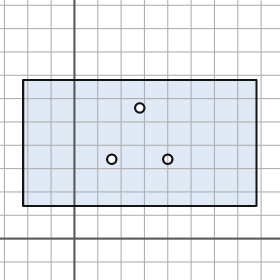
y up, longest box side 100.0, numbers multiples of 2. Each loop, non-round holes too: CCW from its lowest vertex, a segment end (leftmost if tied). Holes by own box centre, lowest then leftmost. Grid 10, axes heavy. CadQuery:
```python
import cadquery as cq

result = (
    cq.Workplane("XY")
    .moveTo(-22.0, 14.0)
    .lineTo(78.0, 14.0)
    .lineTo(78.0, 68.0)
    .lineTo(-22.0, 68.0)
    .close()
    .moveTo(16.0, 34.0)
    .circle(2.0)
    .moveTo(40.0, 34.0)
    .circle(2.0)
    .moveTo(28.0, 56.0)
    .circle(2.0)
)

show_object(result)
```